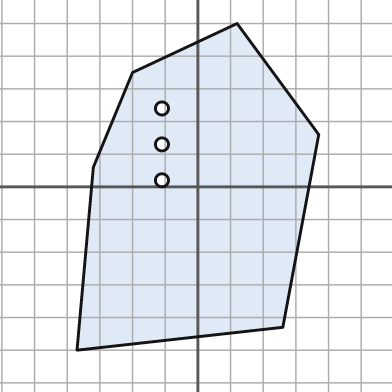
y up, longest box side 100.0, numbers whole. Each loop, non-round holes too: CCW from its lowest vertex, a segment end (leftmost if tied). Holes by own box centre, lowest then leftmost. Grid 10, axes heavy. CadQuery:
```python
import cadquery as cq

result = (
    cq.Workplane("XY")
    .moveTo(-37.0, -50.0)
    .lineTo(26.0, -43.0)
    .lineTo(37.0, 16.0)
    .lineTo(12.0, 50.0)
    .lineTo(-20.0, 35.0)
    .lineTo(-32.0, 6.0)
    .close()
    .moveTo(-11.0, 2.0)
    .circle(2.0)
    .moveTo(-11.0, 13.0)
    .circle(2.0)
    .moveTo(-11.0, 24.0)
    .circle(2.0)
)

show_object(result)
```